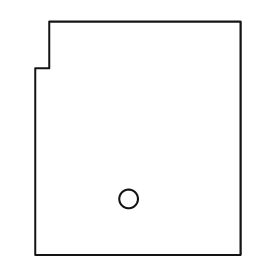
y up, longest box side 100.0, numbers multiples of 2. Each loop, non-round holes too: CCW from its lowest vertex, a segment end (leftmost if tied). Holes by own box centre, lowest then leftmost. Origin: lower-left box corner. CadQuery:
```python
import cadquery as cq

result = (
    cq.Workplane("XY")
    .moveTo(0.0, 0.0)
    .lineTo(88.0, 0.0)
    .lineTo(88.0, 100.0)
    .lineTo(6.0, 100.0)
    .lineTo(6.0, 80.0)
    .lineTo(0.0, 80.0)
    .close()
    .moveTo(40.0, 24.0)
    .circle(4.0)
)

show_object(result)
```